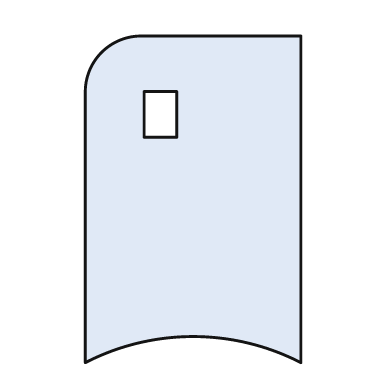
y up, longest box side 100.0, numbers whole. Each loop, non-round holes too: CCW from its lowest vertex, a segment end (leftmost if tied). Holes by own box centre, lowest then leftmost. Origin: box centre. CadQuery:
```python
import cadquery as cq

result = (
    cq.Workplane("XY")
    .moveTo(-33.0, -50.0)
    .threePointArc((0.0, -42.0), (33.0, -50.0))
    .lineTo(33.0, 50.0)
    .lineTo(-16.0, 50.0)
    .threePointArc((-28.0, 45.0), (-33.0, 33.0))
    .close()
    .moveTo(-15.0, 19.0)
    .lineTo(-5.0, 19.0)
    .lineTo(-5.0, 33.0)
    .lineTo(-15.0, 33.0)
    .close()
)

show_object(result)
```